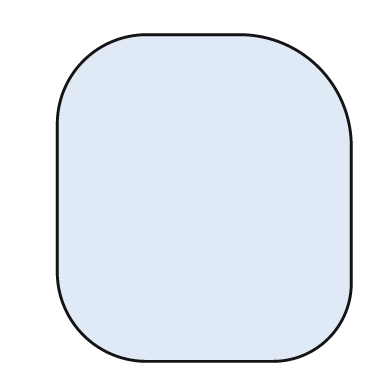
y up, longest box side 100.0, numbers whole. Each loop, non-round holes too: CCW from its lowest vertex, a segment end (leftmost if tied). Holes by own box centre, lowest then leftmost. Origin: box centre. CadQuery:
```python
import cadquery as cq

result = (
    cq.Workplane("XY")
    .moveTo(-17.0, -50.0)
    .lineTo(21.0, -50.0)
    .threePointArc((38.0, -43.0), (45.0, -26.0))
    .lineTo(45.0, 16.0)
    .threePointArc((35.0, 40.0), (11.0, 50.0))
    .lineTo(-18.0, 50.0)
    .threePointArc((-37.0, 42.0), (-45.0, 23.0))
    .lineTo(-45.0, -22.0)
    .threePointArc((-37.0, -42.0), (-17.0, -50.0))
    .close()
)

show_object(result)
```